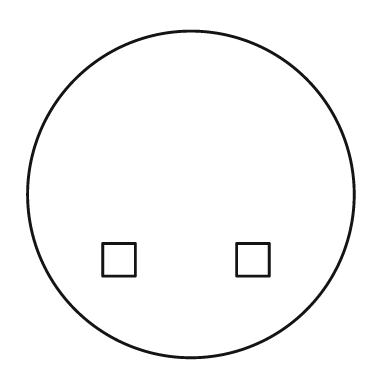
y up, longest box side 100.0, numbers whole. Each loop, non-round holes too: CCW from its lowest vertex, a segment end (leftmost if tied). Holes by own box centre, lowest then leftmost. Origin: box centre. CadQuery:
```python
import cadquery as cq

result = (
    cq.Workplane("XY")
    .moveTo(0.0, 0.0)
    .circle(50.0)
    .moveTo(-27.0, -25.0)
    .lineTo(-17.0, -25.0)
    .lineTo(-17.0, -15.0)
    .lineTo(-27.0, -15.0)
    .close()
    .moveTo(14.0, -25.0)
    .lineTo(24.0, -25.0)
    .lineTo(24.0, -15.0)
    .lineTo(14.0, -15.0)
    .close()
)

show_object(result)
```